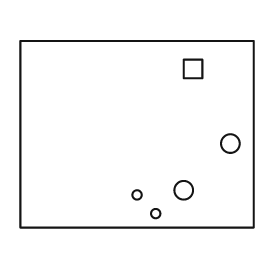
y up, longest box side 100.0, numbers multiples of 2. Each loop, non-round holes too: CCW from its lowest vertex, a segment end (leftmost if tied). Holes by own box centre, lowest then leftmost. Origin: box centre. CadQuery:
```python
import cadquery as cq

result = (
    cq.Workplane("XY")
    .moveTo(-50.0, -40.0)
    .lineTo(50.0, -40.0)
    .lineTo(50.0, 40.0)
    .lineTo(-50.0, 40.0)
    .close()
    .moveTo(8.0, -34.0)
    .circle(2.0)
    .moveTo(0.0, -26.0)
    .circle(2.0)
    .moveTo(20.0, -24.0)
    .circle(4.0)
    .moveTo(40.0, -4.0)
    .circle(4.0)
    .moveTo(20.0, 24.0)
    .lineTo(28.0, 24.0)
    .lineTo(28.0, 32.0)
    .lineTo(20.0, 32.0)
    .close()
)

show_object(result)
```